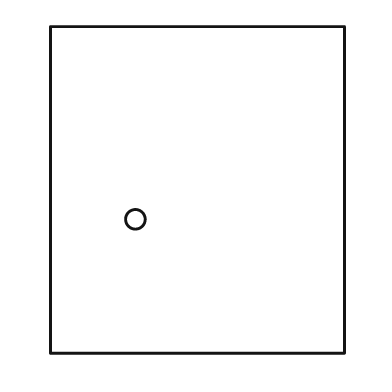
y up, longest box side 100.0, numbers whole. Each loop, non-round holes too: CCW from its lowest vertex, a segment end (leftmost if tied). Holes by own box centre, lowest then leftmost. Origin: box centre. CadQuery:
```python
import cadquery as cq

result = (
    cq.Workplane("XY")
    .moveTo(-45.0, -50.0)
    .lineTo(45.0, -50.0)
    .lineTo(45.0, 50.0)
    .lineTo(-45.0, 50.0)
    .close()
    .moveTo(-19.0, -9.0)
    .circle(3.0)
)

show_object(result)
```